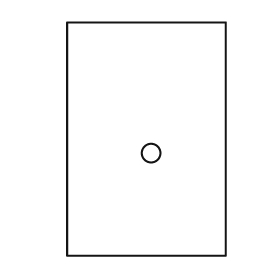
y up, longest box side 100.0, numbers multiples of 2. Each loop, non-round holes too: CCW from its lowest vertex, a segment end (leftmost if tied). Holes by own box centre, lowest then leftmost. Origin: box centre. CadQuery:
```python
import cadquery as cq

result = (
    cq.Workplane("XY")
    .moveTo(-34.0, -50.0)
    .lineTo(34.0, -50.0)
    .lineTo(34.0, 50.0)
    .lineTo(-34.0, 50.0)
    .close()
    .moveTo(2.0, -6.0)
    .circle(4.0)
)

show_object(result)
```